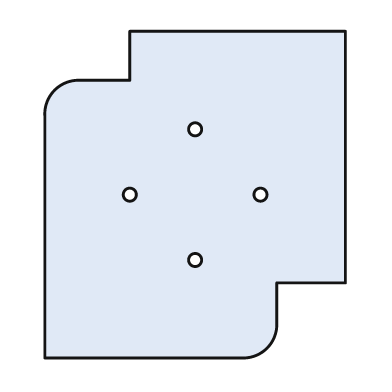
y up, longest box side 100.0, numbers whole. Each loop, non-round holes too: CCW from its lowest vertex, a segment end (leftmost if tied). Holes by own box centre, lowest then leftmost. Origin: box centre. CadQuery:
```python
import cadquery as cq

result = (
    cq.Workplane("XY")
    .moveTo(-46.0, -50.0)
    .lineTo(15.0, -50.0)
    .threePointArc((22.0, -47.0), (25.0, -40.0))
    .lineTo(25.0, -27.0)
    .lineTo(46.0, -27.0)
    .lineTo(46.0, 50.0)
    .lineTo(-20.0, 50.0)
    .lineTo(-20.0, 35.0)
    .lineTo(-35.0, 35.0)
    .threePointArc((-43.0, 32.0), (-46.0, 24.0))
    .close()
    .moveTo(0.0, -20.0)
    .circle(2.0)
    .moveTo(-20.0, 0.0)
    .circle(2.0)
    .moveTo(20.0, 0.0)
    .circle(2.0)
    .moveTo(0.0, 20.0)
    .circle(2.0)
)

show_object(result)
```